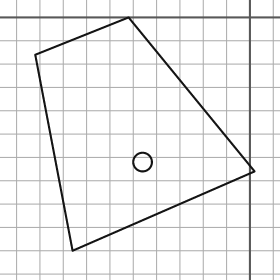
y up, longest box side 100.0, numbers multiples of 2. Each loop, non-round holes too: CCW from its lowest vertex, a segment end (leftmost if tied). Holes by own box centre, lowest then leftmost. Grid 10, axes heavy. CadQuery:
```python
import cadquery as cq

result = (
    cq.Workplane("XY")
    .moveTo(-76.0, -100.0)
    .lineTo(2.0, -66.0)
    .lineTo(-52.0, 0.0)
    .lineTo(-92.0, -16.0)
    .close()
    .moveTo(-46.0, -62.0)
    .circle(4.0)
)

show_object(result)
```